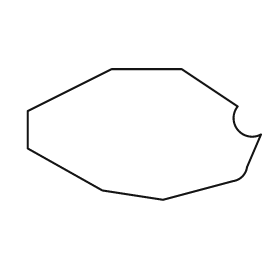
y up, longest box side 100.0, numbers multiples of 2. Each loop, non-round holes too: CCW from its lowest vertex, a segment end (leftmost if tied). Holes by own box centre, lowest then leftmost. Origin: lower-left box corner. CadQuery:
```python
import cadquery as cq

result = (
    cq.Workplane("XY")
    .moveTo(58.0, 0.0)
    .lineTo(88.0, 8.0)
    .threePointArc((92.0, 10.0), (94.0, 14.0))
    .lineTo(100.0, 28.0)
    .threePointArc((90.0, 30.0), (90.0, 40.0))
    .lineTo(66.0, 56.0)
    .lineTo(36.0, 56.0)
    .lineTo(0.0, 38.0)
    .lineTo(0.0, 22.0)
    .lineTo(32.0, 4.0)
    .close()
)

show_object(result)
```